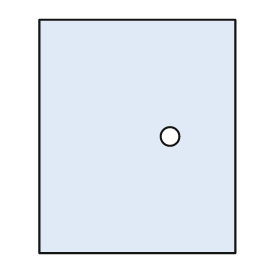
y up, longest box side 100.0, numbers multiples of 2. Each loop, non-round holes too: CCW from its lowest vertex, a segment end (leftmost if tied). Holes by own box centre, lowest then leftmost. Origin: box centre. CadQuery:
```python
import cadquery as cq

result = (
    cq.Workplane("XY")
    .moveTo(-42.0, -50.0)
    .lineTo(42.0, -50.0)
    .lineTo(42.0, 50.0)
    .lineTo(-42.0, 50.0)
    .close()
    .moveTo(14.0, 0.0)
    .circle(4.0)
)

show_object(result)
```